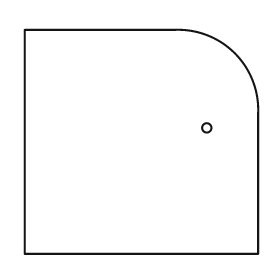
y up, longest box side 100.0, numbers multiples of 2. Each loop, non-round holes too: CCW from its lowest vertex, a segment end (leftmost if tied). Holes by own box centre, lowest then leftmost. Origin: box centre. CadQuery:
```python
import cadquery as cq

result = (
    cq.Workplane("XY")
    .moveTo(-50.0, -48.0)
    .lineTo(50.0, -48.0)
    .lineTo(50.0, 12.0)
    .threePointArc((40.0, 38.0), (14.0, 48.0))
    .lineTo(-50.0, 48.0)
    .close()
    .moveTo(28.0, 6.0)
    .circle(2.0)
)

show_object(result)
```